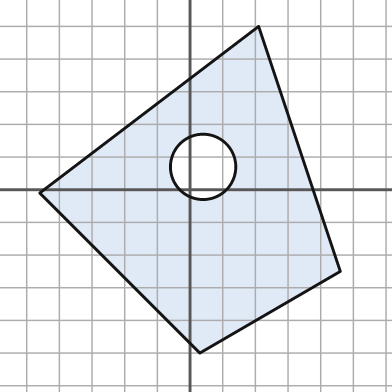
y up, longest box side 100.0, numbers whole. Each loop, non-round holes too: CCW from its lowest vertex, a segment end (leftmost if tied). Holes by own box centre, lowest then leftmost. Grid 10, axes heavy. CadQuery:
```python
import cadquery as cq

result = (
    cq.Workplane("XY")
    .moveTo(3.0, -50.0)
    .lineTo(46.0, -25.0)
    .lineTo(21.0, 50.0)
    .lineTo(-46.0, -1.0)
    .close()
    .moveTo(4.0, 7.0)
    .circle(10.0)
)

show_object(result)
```